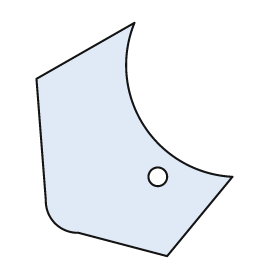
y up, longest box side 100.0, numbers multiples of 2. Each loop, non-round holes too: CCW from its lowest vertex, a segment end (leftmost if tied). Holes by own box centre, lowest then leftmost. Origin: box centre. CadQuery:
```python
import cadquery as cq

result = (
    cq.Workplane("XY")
    .moveTo(14.0, -50.0)
    .lineTo(42.0, -16.0)
    .threePointArc((4.0, 6.0), (0.0, 50.0))
    .lineTo(-42.0, 26.0)
    .lineTo(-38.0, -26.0)
    .threePointArc((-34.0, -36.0), (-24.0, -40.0))
    .close()
    .moveTo(10.0, -16.0)
    .circle(4.0)
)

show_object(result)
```